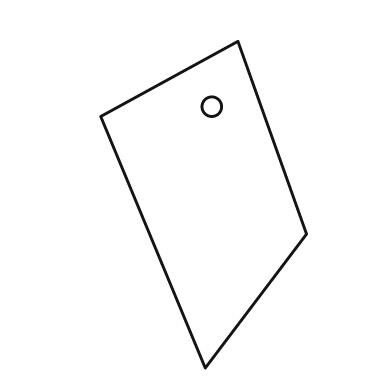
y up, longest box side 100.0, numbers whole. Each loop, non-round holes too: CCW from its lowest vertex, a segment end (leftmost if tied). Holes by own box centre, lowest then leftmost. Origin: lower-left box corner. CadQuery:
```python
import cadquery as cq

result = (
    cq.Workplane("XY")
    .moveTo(32.0, 0.0)
    .lineTo(63.0, 41.0)
    .lineTo(42.0, 100.0)
    .lineTo(0.0, 77.0)
    .close()
    .moveTo(34.0, 80.0)
    .circle(3.0)
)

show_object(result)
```